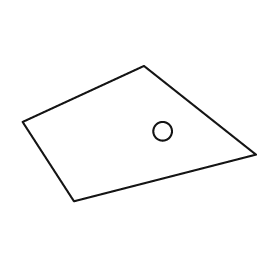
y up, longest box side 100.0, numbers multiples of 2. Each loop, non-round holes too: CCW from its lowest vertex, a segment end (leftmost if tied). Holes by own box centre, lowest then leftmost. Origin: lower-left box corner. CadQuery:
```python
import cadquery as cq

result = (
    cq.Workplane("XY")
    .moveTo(22.0, 0.0)
    .lineTo(100.0, 20.0)
    .lineTo(52.0, 58.0)
    .lineTo(0.0, 34.0)
    .close()
    .moveTo(60.0, 30.0)
    .circle(4.0)
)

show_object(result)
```